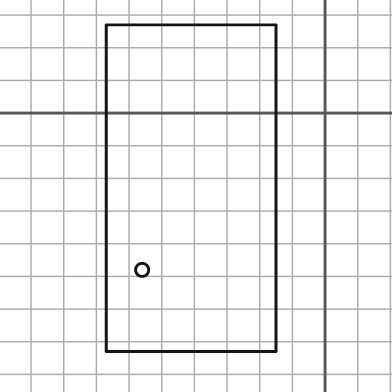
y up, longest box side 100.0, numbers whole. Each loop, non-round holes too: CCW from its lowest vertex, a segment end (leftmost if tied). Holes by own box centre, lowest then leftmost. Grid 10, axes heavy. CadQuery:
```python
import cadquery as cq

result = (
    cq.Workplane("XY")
    .moveTo(-67.0, -73.0)
    .lineTo(-15.0, -73.0)
    .lineTo(-15.0, 27.0)
    .lineTo(-67.0, 27.0)
    .close()
    .moveTo(-56.0, -48.0)
    .circle(2.0)
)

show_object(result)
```